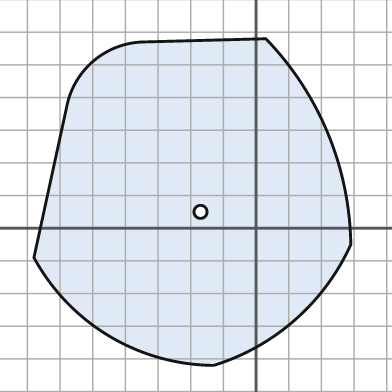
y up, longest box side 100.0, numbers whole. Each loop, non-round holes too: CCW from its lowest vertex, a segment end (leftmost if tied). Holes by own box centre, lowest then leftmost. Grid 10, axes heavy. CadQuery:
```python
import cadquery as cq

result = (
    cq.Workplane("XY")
    .moveTo(-13.0, -42.0)
    .threePointArc((12.0, -28.0), (29.0, -5.0))
    .threePointArc((22.0, 29.0), (3.0, 58.0))
    .lineTo(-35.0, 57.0)
    .threePointArc((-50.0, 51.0), (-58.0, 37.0))
    .lineTo(-68.0, -9.0)
    .threePointArc((-45.0, -33.0), (-13.0, -42.0))
    .close()
    .moveTo(-17.0, 5.0)
    .circle(2.0)
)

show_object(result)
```